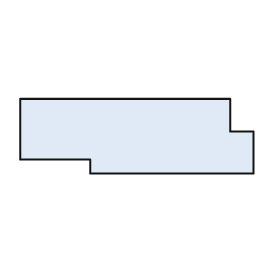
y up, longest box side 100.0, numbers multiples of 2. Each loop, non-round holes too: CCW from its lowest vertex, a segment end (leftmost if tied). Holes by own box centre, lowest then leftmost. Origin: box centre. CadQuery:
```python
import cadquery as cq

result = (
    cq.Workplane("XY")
    .moveTo(-20.0, -16.0)
    .lineTo(50.0, -16.0)
    .lineTo(50.0, 2.0)
    .lineTo(40.0, 2.0)
    .lineTo(40.0, 16.0)
    .lineTo(-50.0, 16.0)
    .lineTo(-50.0, -10.0)
    .lineTo(-20.0, -10.0)
    .close()
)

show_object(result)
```